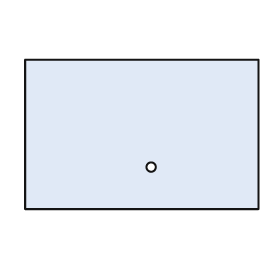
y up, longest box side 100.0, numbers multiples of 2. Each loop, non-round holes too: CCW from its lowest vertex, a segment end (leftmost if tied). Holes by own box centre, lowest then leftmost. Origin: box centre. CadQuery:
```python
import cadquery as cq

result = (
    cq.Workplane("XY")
    .moveTo(-50.0, -32.0)
    .lineTo(50.0, -32.0)
    .lineTo(50.0, 32.0)
    .lineTo(-50.0, 32.0)
    .close()
    .moveTo(4.0, -14.0)
    .circle(2.0)
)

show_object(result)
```